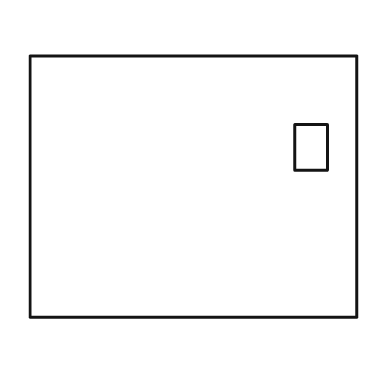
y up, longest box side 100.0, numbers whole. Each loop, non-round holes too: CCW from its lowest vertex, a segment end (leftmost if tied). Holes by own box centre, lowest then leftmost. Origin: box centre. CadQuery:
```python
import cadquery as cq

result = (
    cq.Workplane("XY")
    .moveTo(-50.0, -40.0)
    .lineTo(50.0, -40.0)
    .lineTo(50.0, 40.0)
    .lineTo(-50.0, 40.0)
    .close()
    .moveTo(31.0, 5.0)
    .lineTo(41.0, 5.0)
    .lineTo(41.0, 19.0)
    .lineTo(31.0, 19.0)
    .close()
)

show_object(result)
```